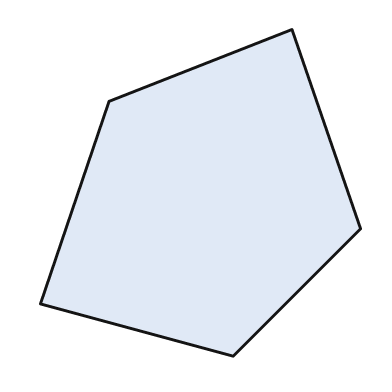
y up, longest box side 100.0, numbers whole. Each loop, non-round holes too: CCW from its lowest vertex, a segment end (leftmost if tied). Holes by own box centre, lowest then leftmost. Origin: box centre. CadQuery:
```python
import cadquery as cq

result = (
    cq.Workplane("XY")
    .moveTo(10.0, -50.0)
    .lineTo(49.0, -11.0)
    .lineTo(28.0, 50.0)
    .lineTo(-28.0, 28.0)
    .lineTo(-49.0, -34.0)
    .close()
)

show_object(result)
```